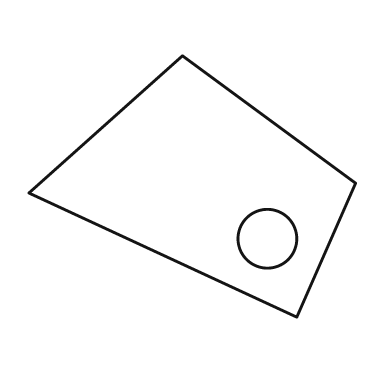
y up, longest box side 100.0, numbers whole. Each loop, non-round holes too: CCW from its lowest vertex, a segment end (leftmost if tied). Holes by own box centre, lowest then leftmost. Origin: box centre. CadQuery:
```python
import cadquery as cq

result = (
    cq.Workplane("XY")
    .moveTo(32.0, -40.0)
    .lineTo(50.0, 1.0)
    .lineTo(-3.0, 40.0)
    .lineTo(-50.0, -2.0)
    .close()
    .moveTo(23.0, -16.0)
    .circle(9.0)
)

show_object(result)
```